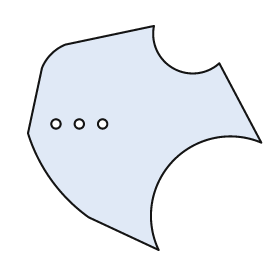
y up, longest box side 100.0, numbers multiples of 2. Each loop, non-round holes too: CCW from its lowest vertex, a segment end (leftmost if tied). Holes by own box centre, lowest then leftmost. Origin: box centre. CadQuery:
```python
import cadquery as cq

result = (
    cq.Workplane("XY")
    .moveTo(6.0, -48.0)
    .threePointArc((12.0, -10.0), (50.0, -2.0))
    .lineTo(32.0, 32.0)
    .threePointArc((12.0, 30.0), (4.0, 48.0))
    .lineTo(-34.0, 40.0)
    .threePointArc((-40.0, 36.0), (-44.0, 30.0))
    .lineTo(-50.0, 2.0)
    .threePointArc((-40.0, -18.0), (-24.0, -34.0))
    .close()
    .moveTo(-38.0, 6.0)
    .circle(2.0)
    .moveTo(-28.0, 6.0)
    .circle(2.0)
    .moveTo(-18.0, 6.0)
    .circle(2.0)
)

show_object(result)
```